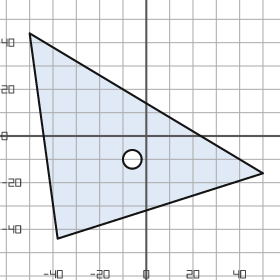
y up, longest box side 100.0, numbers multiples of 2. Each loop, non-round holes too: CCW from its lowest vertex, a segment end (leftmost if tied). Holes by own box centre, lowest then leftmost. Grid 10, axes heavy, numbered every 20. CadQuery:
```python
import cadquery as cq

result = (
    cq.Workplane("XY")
    .moveTo(-38.0, -44.0)
    .lineTo(50.0, -16.0)
    .lineTo(-50.0, 44.0)
    .close()
    .moveTo(-6.0, -10.0)
    .circle(4.0)
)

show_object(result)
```